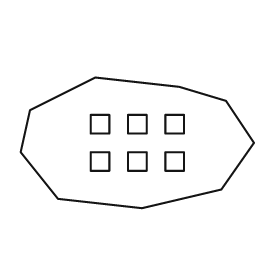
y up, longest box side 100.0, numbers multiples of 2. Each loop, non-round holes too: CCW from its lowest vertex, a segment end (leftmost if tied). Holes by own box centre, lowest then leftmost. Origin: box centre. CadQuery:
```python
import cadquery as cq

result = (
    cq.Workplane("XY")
    .moveTo(2.0, -28.0)
    .lineTo(36.0, -20.0)
    .lineTo(50.0, 0.0)
    .lineTo(38.0, 18.0)
    .lineTo(18.0, 24.0)
    .lineTo(-18.0, 28.0)
    .lineTo(-46.0, 14.0)
    .lineTo(-50.0, -4.0)
    .lineTo(-34.0, -24.0)
    .close()
    .moveTo(-20.0, -12.0)
    .lineTo(-12.0, -12.0)
    .lineTo(-12.0, -4.0)
    .lineTo(-20.0, -4.0)
    .close()
    .moveTo(-4.0, -12.0)
    .lineTo(4.0, -12.0)
    .lineTo(4.0, -4.0)
    .lineTo(-4.0, -4.0)
    .close()
    .moveTo(12.0, -12.0)
    .lineTo(20.0, -12.0)
    .lineTo(20.0, -4.0)
    .lineTo(12.0, -4.0)
    .close()
    .moveTo(-20.0, 4.0)
    .lineTo(-12.0, 4.0)
    .lineTo(-12.0, 12.0)
    .lineTo(-20.0, 12.0)
    .close()
    .moveTo(-4.0, 4.0)
    .lineTo(4.0, 4.0)
    .lineTo(4.0, 12.0)
    .lineTo(-4.0, 12.0)
    .close()
    .moveTo(12.0, 4.0)
    .lineTo(20.0, 4.0)
    .lineTo(20.0, 12.0)
    .lineTo(12.0, 12.0)
    .close()
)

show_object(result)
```